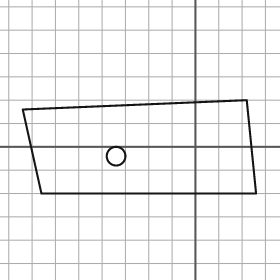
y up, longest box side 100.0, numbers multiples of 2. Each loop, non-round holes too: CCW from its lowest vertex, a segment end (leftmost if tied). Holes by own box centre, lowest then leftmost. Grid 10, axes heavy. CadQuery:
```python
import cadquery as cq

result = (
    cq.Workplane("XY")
    .moveTo(-66.0, -20.0)
    .lineTo(26.0, -20.0)
    .lineTo(22.0, 20.0)
    .lineTo(-74.0, 16.0)
    .close()
    .moveTo(-34.0, -4.0)
    .circle(4.0)
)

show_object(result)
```